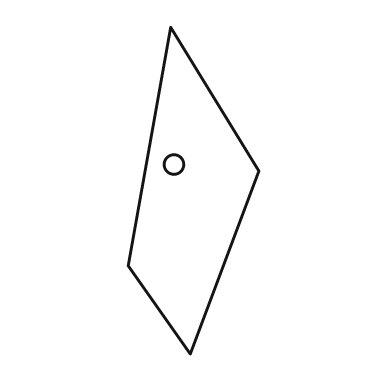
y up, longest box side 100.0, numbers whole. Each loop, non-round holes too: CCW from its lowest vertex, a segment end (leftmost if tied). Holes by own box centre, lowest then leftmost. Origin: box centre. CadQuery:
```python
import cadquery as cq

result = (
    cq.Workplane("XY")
    .moveTo(-1.0, -50.0)
    .lineTo(20.0, 6.0)
    .lineTo(-7.0, 50.0)
    .lineTo(-20.0, -23.0)
    .close()
    .moveTo(-6.0, 8.0)
    .circle(3.0)
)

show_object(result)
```